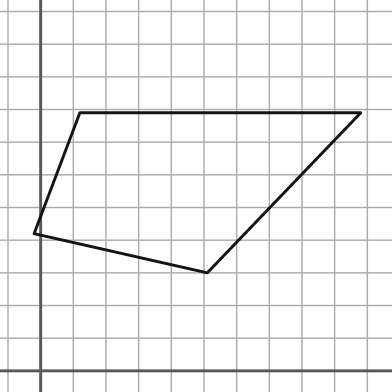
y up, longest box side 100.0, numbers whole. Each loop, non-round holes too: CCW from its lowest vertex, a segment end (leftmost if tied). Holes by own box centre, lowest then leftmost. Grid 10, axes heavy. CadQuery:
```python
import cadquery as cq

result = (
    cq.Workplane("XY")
    .moveTo(51.0, 30.0)
    .lineTo(98.0, 79.0)
    .lineTo(12.0, 79.0)
    .lineTo(-2.0, 42.0)
    .close()
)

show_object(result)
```